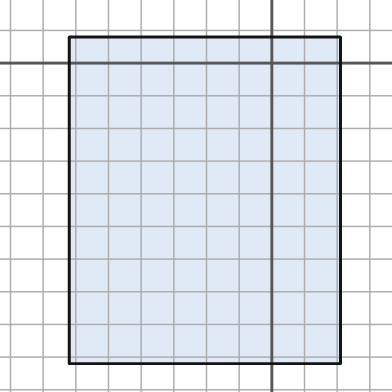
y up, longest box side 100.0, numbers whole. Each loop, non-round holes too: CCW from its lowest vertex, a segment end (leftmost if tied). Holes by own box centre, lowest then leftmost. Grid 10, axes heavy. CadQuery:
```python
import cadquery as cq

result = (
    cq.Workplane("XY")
    .moveTo(-62.0, -92.0)
    .lineTo(21.0, -92.0)
    .lineTo(21.0, 8.0)
    .lineTo(-62.0, 8.0)
    .close()
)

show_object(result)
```